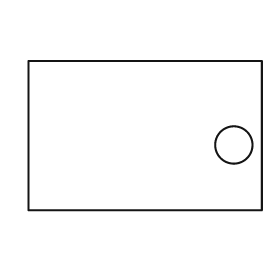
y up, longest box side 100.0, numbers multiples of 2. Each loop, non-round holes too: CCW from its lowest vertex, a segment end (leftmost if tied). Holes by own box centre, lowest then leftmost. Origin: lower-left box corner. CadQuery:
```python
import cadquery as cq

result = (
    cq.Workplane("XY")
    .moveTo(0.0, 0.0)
    .lineTo(100.0, 0.0)
    .lineTo(100.0, 64.0)
    .lineTo(0.0, 64.0)
    .close()
    .moveTo(88.0, 28.0)
    .circle(8.0)
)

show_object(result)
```